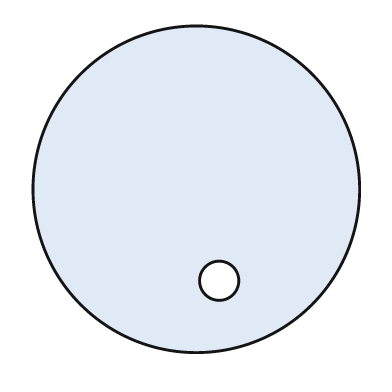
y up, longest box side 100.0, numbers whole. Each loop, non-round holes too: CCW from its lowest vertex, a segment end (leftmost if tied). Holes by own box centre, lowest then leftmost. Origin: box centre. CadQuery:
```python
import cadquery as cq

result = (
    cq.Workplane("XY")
    .moveTo(0.0, 0.0)
    .circle(50.0)
    .moveTo(7.0, -28.0)
    .circle(6.0)
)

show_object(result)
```